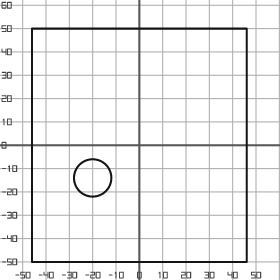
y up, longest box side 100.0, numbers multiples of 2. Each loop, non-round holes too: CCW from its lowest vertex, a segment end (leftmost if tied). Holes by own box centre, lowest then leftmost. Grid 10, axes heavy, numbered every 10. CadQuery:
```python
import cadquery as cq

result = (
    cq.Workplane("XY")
    .moveTo(-46.0, -50.0)
    .lineTo(46.0, -50.0)
    .lineTo(46.0, 50.0)
    .lineTo(-46.0, 50.0)
    .close()
    .moveTo(-20.0, -14.0)
    .circle(8.0)
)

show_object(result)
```